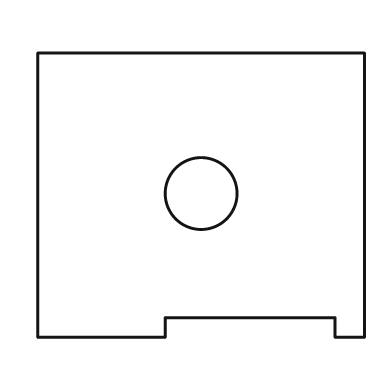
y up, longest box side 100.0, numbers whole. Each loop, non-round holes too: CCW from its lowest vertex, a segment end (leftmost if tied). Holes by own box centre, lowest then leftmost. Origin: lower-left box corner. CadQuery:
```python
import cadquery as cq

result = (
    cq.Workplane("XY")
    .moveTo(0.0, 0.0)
    .lineTo(39.0, 0.0)
    .lineTo(39.0, 6.0)
    .lineTo(91.0, 6.0)
    .lineTo(91.0, 0.0)
    .lineTo(100.0, 0.0)
    .lineTo(100.0, 87.0)
    .lineTo(0.0, 87.0)
    .close()
    .moveTo(50.0, 44.0)
    .circle(11.0)
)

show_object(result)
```